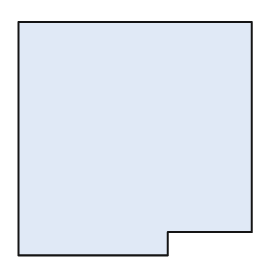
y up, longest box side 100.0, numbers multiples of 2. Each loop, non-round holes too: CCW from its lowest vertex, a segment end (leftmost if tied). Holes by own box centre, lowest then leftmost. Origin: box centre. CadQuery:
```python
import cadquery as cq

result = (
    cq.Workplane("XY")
    .moveTo(-50.0, -50.0)
    .lineTo(14.0, -50.0)
    .lineTo(14.0, -40.0)
    .lineTo(50.0, -40.0)
    .lineTo(50.0, 50.0)
    .lineTo(-50.0, 50.0)
    .close()
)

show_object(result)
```